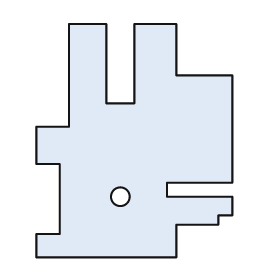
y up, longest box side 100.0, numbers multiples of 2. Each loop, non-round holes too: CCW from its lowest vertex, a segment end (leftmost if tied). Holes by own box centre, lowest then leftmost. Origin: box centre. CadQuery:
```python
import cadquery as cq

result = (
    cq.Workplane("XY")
    .moveTo(-42.0, -50.0)
    .lineTo(18.0, -50.0)
    .lineTo(18.0, -36.0)
    .lineTo(36.0, -36.0)
    .lineTo(36.0, -32.0)
    .lineTo(42.0, -32.0)
    .lineTo(42.0, -24.0)
    .lineTo(14.0, -24.0)
    .lineTo(14.0, -18.0)
    .lineTo(42.0, -18.0)
    .lineTo(42.0, 28.0)
    .lineTo(18.0, 28.0)
    .lineTo(18.0, 50.0)
    .lineTo(0.0, 50.0)
    .lineTo(0.0, 16.0)
    .lineTo(-12.0, 16.0)
    .lineTo(-12.0, 50.0)
    .lineTo(-28.0, 50.0)
    .lineTo(-28.0, 6.0)
    .lineTo(-42.0, 6.0)
    .lineTo(-42.0, -10.0)
    .lineTo(-32.0, -10.0)
    .lineTo(-32.0, -40.0)
    .lineTo(-42.0, -40.0)
    .close()
    .moveTo(-6.0, -24.0)
    .circle(4.0)
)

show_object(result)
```